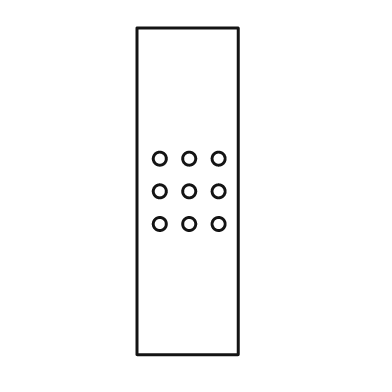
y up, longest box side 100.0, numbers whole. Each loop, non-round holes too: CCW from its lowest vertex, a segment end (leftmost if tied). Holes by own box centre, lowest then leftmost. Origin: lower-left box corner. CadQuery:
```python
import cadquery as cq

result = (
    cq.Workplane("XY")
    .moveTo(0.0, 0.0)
    .lineTo(31.0, 0.0)
    .lineTo(31.0, 100.0)
    .lineTo(0.0, 100.0)
    .close()
    .moveTo(7.0, 40.0)
    .circle(2.0)
    .moveTo(16.0, 40.0)
    .circle(2.0)
    .moveTo(25.0, 40.0)
    .circle(2.0)
    .moveTo(7.0, 50.0)
    .circle(2.0)
    .moveTo(16.0, 50.0)
    .circle(2.0)
    .moveTo(25.0, 50.0)
    .circle(2.0)
    .moveTo(7.0, 60.0)
    .circle(2.0)
    .moveTo(16.0, 60.0)
    .circle(2.0)
    .moveTo(25.0, 60.0)
    .circle(2.0)
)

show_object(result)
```